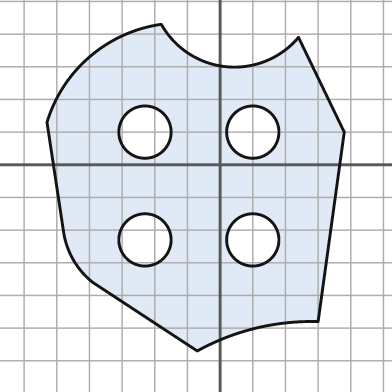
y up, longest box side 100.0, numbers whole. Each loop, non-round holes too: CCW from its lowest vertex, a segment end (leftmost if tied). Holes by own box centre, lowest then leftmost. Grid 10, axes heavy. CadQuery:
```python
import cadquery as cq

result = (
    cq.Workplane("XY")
    .moveTo(-7.0, -57.0)
    .threePointArc((11.0, -50.0), (30.0, -48.0))
    .lineTo(38.0, 10.0)
    .lineTo(24.0, 39.0)
    .threePointArc((2.0, 30.0), (-18.0, 43.0))
    .threePointArc((-40.0, 33.0), (-53.0, 13.0))
    .lineTo(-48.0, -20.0)
    .threePointArc((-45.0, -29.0), (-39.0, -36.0))
    .close()
    .moveTo(-23.0, -23.0)
    .circle(8.0)
    .moveTo(10.0, -23.0)
    .circle(8.0)
    .moveTo(-23.0, 10.0)
    .circle(8.0)
    .moveTo(10.0, 10.0)
    .circle(8.0)
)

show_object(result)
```